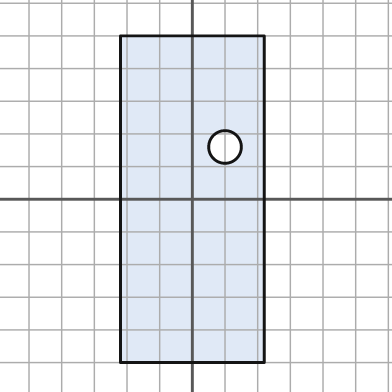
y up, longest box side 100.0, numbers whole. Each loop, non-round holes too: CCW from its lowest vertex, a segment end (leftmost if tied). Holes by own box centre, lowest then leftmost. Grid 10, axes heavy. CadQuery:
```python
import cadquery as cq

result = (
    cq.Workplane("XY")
    .moveTo(-22.0, -50.0)
    .lineTo(22.0, -50.0)
    .lineTo(22.0, 50.0)
    .lineTo(-22.0, 50.0)
    .close()
    .moveTo(10.0, 16.0)
    .circle(5.0)
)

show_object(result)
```